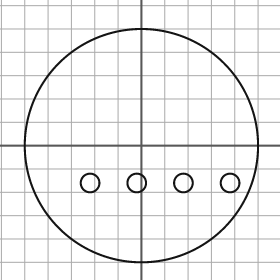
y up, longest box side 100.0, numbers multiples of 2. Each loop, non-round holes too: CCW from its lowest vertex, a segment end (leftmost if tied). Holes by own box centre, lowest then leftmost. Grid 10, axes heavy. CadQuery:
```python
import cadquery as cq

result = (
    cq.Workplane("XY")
    .moveTo(0.0, 0.0)
    .circle(50.0)
    .moveTo(-22.0, -16.0)
    .circle(4.0)
    .moveTo(-2.0, -16.0)
    .circle(4.0)
    .moveTo(18.0, -16.0)
    .circle(4.0)
    .moveTo(38.0, -16.0)
    .circle(4.0)
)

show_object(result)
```